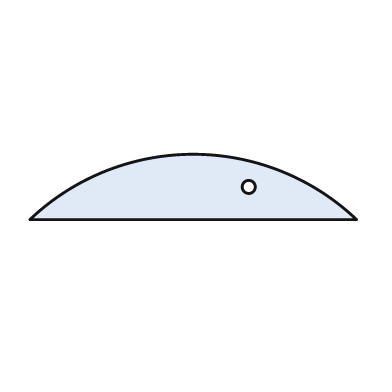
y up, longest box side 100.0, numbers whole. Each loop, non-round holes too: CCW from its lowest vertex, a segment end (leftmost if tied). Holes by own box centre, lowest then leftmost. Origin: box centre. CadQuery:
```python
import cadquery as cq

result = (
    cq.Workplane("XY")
    .moveTo(-50.0, -10.0)
    .lineTo(50.0, -10.0)
    .threePointArc((0.0, 10.0), (-50.0, -10.0))
    .close()
    .moveTo(17.0, 0.0)
    .circle(2.0)
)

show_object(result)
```